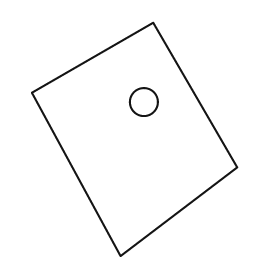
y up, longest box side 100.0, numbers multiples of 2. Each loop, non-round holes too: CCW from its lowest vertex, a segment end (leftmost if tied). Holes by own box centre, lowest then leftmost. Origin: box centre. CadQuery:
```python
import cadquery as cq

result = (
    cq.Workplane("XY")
    .moveTo(-6.0, -50.0)
    .lineTo(44.0, -12.0)
    .lineTo(8.0, 50.0)
    .lineTo(-44.0, 20.0)
    .close()
    .moveTo(4.0, 16.0)
    .circle(6.0)
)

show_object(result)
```